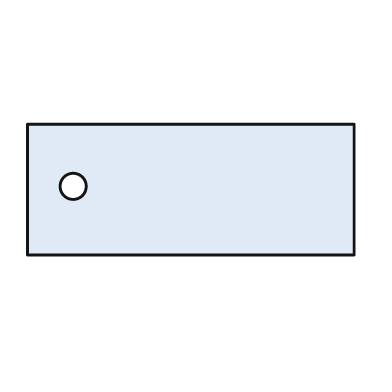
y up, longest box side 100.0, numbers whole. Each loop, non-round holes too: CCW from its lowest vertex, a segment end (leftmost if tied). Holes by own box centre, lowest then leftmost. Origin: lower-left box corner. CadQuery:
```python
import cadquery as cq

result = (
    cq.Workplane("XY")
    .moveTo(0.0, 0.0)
    .lineTo(100.0, 0.0)
    .lineTo(100.0, 40.0)
    .lineTo(0.0, 40.0)
    .close()
    .moveTo(14.0, 21.0)
    .circle(4.0)
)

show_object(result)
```